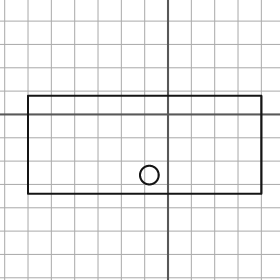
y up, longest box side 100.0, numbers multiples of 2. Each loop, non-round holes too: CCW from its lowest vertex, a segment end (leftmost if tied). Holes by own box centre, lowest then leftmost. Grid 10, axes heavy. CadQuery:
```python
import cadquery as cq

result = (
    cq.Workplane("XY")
    .moveTo(-60.0, -34.0)
    .lineTo(40.0, -34.0)
    .lineTo(40.0, 8.0)
    .lineTo(-60.0, 8.0)
    .close()
    .moveTo(-8.0, -26.0)
    .circle(4.0)
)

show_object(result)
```